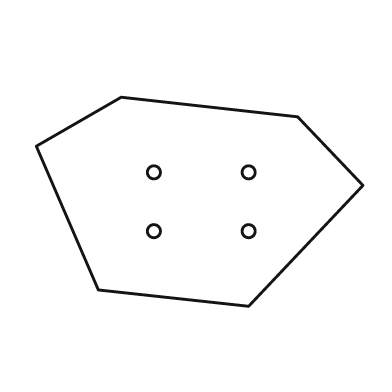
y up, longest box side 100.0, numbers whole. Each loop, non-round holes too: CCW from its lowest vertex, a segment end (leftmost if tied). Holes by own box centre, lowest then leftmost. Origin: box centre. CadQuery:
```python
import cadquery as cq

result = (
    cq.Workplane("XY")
    .moveTo(15.0, -32.0)
    .lineTo(50.0, 5.0)
    .lineTo(30.0, 26.0)
    .lineTo(-24.0, 32.0)
    .lineTo(-50.0, 17.0)
    .lineTo(-31.0, -27.0)
    .close()
    .moveTo(-14.0, -9.0)
    .circle(2.0)
    .moveTo(15.0, -9.0)
    .circle(2.0)
    .moveTo(-14.0, 9.0)
    .circle(2.0)
    .moveTo(15.0, 9.0)
    .circle(2.0)
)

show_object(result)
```